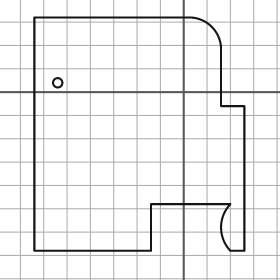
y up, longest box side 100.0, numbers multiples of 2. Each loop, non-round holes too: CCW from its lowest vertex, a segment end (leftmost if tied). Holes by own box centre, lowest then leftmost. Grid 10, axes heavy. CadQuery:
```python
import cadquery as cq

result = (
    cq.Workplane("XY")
    .moveTo(-64.0, -68.0)
    .lineTo(-14.0, -68.0)
    .lineTo(-14.0, -48.0)
    .lineTo(20.0, -48.0)
    .threePointArc((16.0, -58.0), (20.0, -68.0))
    .lineTo(26.0, -68.0)
    .lineTo(26.0, -6.0)
    .lineTo(16.0, -6.0)
    .lineTo(16.0, 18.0)
    .threePointArc((12.0, 28.0), (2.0, 32.0))
    .lineTo(-64.0, 32.0)
    .close()
    .moveTo(-54.0, 4.0)
    .circle(2.0)
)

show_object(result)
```